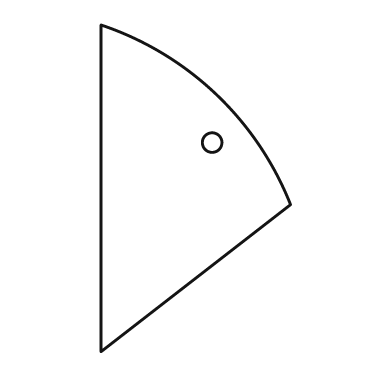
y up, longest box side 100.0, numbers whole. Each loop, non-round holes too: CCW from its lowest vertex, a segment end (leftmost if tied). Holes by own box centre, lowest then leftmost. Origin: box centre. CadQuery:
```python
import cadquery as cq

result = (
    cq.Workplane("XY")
    .moveTo(-29.0, -50.0)
    .lineTo(29.0, -5.0)
    .threePointArc((6.0, 29.0), (-29.0, 50.0))
    .close()
    .moveTo(5.0, 14.0)
    .circle(3.0)
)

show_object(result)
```